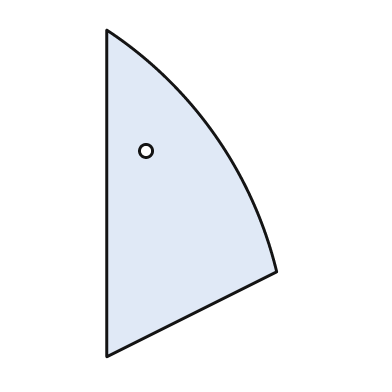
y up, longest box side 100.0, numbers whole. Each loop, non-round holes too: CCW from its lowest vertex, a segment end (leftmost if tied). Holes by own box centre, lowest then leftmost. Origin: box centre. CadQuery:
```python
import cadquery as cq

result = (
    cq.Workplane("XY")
    .moveTo(-26.0, -50.0)
    .lineTo(26.0, -24.0)
    .threePointArc((7.0, 18.0), (-26.0, 50.0))
    .close()
    .moveTo(-14.0, 13.0)
    .circle(2.0)
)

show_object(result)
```